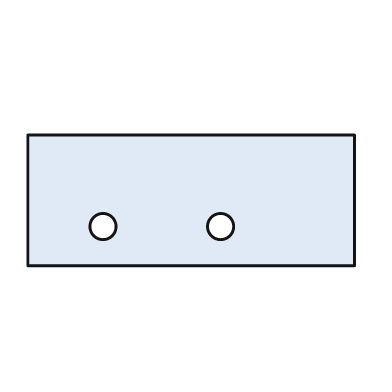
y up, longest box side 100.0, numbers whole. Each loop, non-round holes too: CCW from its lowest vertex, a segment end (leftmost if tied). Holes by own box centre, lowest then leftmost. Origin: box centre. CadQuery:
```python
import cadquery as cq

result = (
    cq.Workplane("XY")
    .moveTo(-50.0, -20.0)
    .lineTo(50.0, -20.0)
    .lineTo(50.0, 20.0)
    .lineTo(-50.0, 20.0)
    .close()
    .moveTo(-27.0, -8.0)
    .circle(4.0)
    .moveTo(9.0, -8.0)
    .circle(4.0)
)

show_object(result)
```